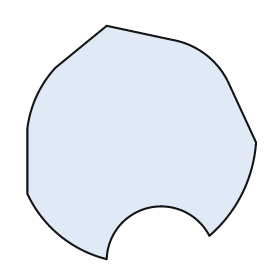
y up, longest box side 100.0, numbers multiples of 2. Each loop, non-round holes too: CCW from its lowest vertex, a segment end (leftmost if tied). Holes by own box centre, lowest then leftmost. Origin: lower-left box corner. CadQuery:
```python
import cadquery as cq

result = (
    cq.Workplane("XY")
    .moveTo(34.0, 0.0)
    .threePointArc((52.0, 22.0), (78.0, 10.0))
    .threePointArc((92.0, 28.0), (98.0, 50.0))
    .lineTo(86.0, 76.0)
    .threePointArc((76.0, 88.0), (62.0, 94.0))
    .lineTo(34.0, 100.0)
    .lineTo(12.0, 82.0)
    .threePointArc((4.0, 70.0), (0.0, 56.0))
    .lineTo(0.0, 28.0)
    .threePointArc((14.0, 10.0), (34.0, 0.0))
    .close()
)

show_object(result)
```